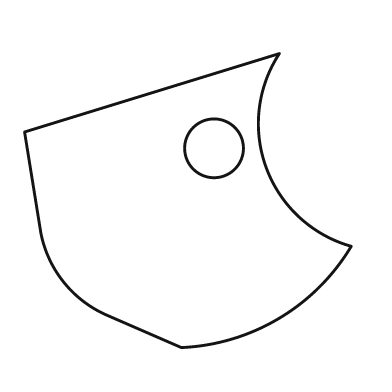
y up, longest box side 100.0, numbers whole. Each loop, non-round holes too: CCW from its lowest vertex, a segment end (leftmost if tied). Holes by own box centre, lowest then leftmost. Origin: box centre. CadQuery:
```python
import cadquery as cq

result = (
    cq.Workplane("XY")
    .moveTo(-2.0, -45.0)
    .threePointArc((28.0, -36.0), (50.0, -14.0))
    .threePointArc((24.0, 10.0), (28.0, 45.0))
    .lineTo(-50.0, 21.0)
    .lineTo(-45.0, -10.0)
    .threePointArc((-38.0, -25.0), (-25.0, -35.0))
    .close()
    .moveTo(8.0, 16.0)
    .circle(9.0)
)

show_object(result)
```